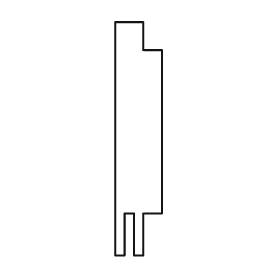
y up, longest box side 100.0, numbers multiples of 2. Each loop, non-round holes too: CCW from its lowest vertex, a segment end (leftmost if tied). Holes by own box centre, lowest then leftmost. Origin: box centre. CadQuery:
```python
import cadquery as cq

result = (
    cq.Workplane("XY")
    .moveTo(-10.0, -50.0)
    .lineTo(-6.0, -50.0)
    .lineTo(-6.0, -32.0)
    .lineTo(-2.0, -32.0)
    .lineTo(-2.0, -50.0)
    .lineTo(2.0, -50.0)
    .lineTo(2.0, -32.0)
    .lineTo(10.0, -32.0)
    .lineTo(10.0, 38.0)
    .lineTo(2.0, 38.0)
    .lineTo(2.0, 50.0)
    .lineTo(-10.0, 50.0)
    .close()
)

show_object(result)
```